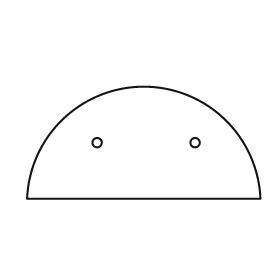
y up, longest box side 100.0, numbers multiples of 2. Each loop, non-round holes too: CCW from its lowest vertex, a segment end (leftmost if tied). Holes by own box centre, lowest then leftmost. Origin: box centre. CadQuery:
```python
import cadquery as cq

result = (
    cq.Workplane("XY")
    .moveTo(-50.0, -24.0)
    .lineTo(50.0, -24.0)
    .threePointArc((0.0, 24.0), (-50.0, -24.0))
    .close()
    .moveTo(-20.0, 0.0)
    .circle(2.0)
    .moveTo(22.0, 0.0)
    .circle(2.0)
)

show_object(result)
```